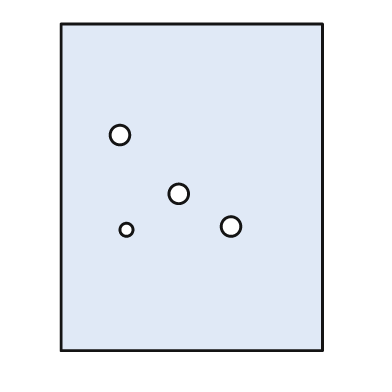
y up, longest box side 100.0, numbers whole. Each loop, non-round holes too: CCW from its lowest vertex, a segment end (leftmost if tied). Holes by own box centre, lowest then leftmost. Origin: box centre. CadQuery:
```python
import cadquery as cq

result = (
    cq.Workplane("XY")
    .moveTo(-40.0, -50.0)
    .lineTo(40.0, -50.0)
    .lineTo(40.0, 50.0)
    .lineTo(-40.0, 50.0)
    .close()
    .moveTo(-20.0, -13.0)
    .circle(2.0)
    .moveTo(12.0, -12.0)
    .circle(3.0)
    .moveTo(-4.0, -2.0)
    .circle(3.0)
    .moveTo(-22.0, 16.0)
    .circle(3.0)
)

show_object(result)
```